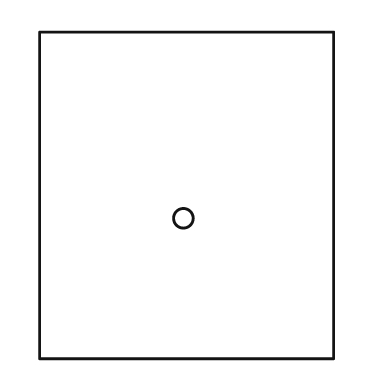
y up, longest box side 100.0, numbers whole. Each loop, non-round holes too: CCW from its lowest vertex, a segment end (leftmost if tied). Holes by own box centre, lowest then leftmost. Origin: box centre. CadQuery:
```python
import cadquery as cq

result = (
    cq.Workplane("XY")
    .moveTo(-45.0, -50.0)
    .lineTo(45.0, -50.0)
    .lineTo(45.0, 50.0)
    .lineTo(-45.0, 50.0)
    .close()
    .moveTo(-1.0, -7.0)
    .circle(3.0)
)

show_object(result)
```